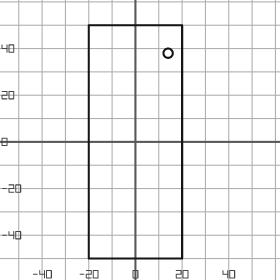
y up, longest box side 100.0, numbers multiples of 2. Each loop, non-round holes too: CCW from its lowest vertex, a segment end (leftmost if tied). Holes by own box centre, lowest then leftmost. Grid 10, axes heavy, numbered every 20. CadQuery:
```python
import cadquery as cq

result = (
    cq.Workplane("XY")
    .moveTo(-20.0, -50.0)
    .lineTo(20.0, -50.0)
    .lineTo(20.0, 50.0)
    .lineTo(-20.0, 50.0)
    .close()
    .moveTo(14.0, 38.0)
    .circle(2.0)
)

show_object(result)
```